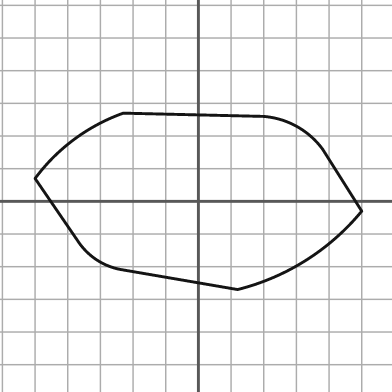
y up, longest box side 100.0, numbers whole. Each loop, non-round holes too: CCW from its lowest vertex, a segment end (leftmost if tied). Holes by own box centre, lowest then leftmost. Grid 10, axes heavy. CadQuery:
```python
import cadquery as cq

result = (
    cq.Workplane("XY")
    .moveTo(12.0, -27.0)
    .threePointArc((33.0, -18.0), (50.0, -3.0))
    .lineTo(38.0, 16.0)
    .threePointArc((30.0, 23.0), (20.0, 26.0))
    .lineTo(-23.0, 27.0)
    .threePointArc((-38.0, 19.0), (-50.0, 7.0))
    .lineTo(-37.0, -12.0)
    .threePointArc((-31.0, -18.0), (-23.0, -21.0))
    .close()
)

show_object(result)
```